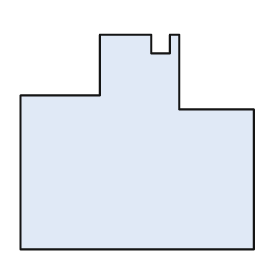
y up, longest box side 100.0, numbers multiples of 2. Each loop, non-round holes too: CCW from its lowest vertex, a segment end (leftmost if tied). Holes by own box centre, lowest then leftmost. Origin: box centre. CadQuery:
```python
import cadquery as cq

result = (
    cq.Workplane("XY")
    .moveTo(-50.0, -46.0)
    .lineTo(50.0, -46.0)
    .lineTo(50.0, 14.0)
    .lineTo(18.0, 14.0)
    .lineTo(18.0, 46.0)
    .lineTo(14.0, 46.0)
    .lineTo(14.0, 38.0)
    .lineTo(6.0, 38.0)
    .lineTo(6.0, 46.0)
    .lineTo(-16.0, 46.0)
    .lineTo(-16.0, 20.0)
    .lineTo(-50.0, 20.0)
    .close()
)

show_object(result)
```